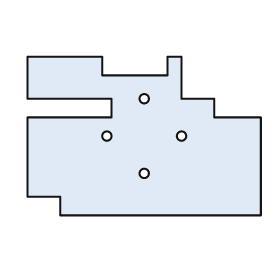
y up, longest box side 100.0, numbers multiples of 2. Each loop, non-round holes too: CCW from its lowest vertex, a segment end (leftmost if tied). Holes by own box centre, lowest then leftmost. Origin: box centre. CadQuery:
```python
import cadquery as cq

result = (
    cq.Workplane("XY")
    .moveTo(-36.0, -34.0)
    .lineTo(50.0, -34.0)
    .lineTo(50.0, 8.0)
    .lineTo(30.0, 8.0)
    .lineTo(30.0, 16.0)
    .lineTo(16.0, 16.0)
    .lineTo(16.0, 34.0)
    .lineTo(10.0, 34.0)
    .lineTo(10.0, 26.0)
    .lineTo(-18.0, 26.0)
    .lineTo(-18.0, 34.0)
    .lineTo(-50.0, 34.0)
    .lineTo(-50.0, 16.0)
    .lineTo(-14.0, 16.0)
    .lineTo(-14.0, 8.0)
    .lineTo(-50.0, 8.0)
    .lineTo(-50.0, -26.0)
    .lineTo(-36.0, -26.0)
    .close()
    .moveTo(0.0, -16.0)
    .circle(2.0)
    .moveTo(-16.0, 0.0)
    .circle(2.0)
    .moveTo(16.0, 0.0)
    .circle(2.0)
    .moveTo(0.0, 16.0)
    .circle(2.0)
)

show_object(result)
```